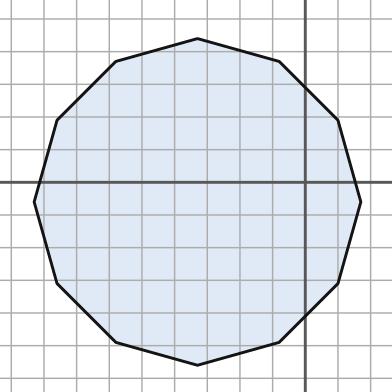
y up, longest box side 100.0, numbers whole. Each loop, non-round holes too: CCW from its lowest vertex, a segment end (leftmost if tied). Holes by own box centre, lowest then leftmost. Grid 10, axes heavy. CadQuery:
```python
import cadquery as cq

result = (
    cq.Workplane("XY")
    .moveTo(-33.0, -56.0)
    .lineTo(-8.0, -49.0)
    .lineTo(10.0, -31.0)
    .lineTo(17.0, -6.0)
    .lineTo(10.0, 19.0)
    .lineTo(-8.0, 37.0)
    .lineTo(-33.0, 44.0)
    .lineTo(-58.0, 37.0)
    .lineTo(-76.0, 19.0)
    .lineTo(-83.0, -6.0)
    .lineTo(-76.0, -31.0)
    .lineTo(-58.0, -49.0)
    .close()
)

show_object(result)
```